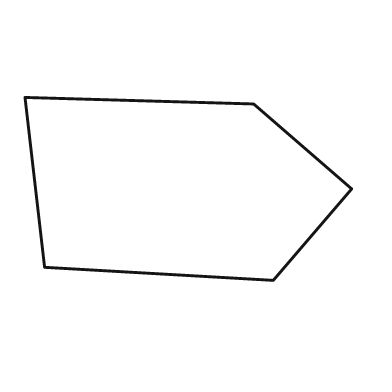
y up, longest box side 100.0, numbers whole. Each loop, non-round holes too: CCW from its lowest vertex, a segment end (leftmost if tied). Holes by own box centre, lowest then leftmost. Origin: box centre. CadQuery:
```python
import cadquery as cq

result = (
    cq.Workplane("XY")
    .moveTo(26.0, -28.0)
    .lineTo(50.0, 0.0)
    .lineTo(20.0, 26.0)
    .lineTo(-50.0, 28.0)
    .lineTo(-44.0, -24.0)
    .close()
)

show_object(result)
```